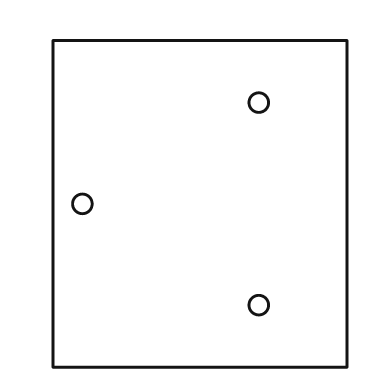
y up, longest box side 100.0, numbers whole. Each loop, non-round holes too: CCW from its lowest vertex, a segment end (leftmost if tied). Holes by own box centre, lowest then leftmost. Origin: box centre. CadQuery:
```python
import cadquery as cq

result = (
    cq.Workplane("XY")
    .moveTo(-45.0, -50.0)
    .lineTo(45.0, -50.0)
    .lineTo(45.0, 50.0)
    .lineTo(-45.0, 50.0)
    .close()
    .moveTo(18.0, -31.0)
    .circle(3.0)
    .moveTo(-36.0, 0.0)
    .circle(3.0)
    .moveTo(18.0, 31.0)
    .circle(3.0)
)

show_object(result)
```